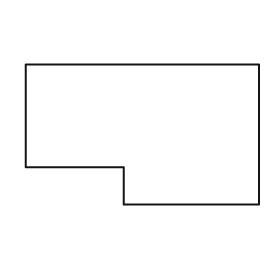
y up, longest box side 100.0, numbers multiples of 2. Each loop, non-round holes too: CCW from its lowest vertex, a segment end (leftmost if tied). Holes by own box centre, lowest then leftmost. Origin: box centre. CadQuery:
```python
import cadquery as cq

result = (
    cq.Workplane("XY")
    .moveTo(-8.0, -30.0)
    .lineTo(50.0, -30.0)
    .lineTo(50.0, 30.0)
    .lineTo(-50.0, 30.0)
    .lineTo(-50.0, -14.0)
    .lineTo(-8.0, -14.0)
    .close()
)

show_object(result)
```